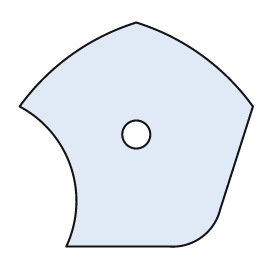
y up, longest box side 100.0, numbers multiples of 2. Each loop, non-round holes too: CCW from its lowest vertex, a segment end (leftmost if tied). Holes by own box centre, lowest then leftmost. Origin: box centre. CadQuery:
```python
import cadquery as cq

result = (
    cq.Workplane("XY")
    .moveTo(-30.0, -48.0)
    .lineTo(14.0, -48.0)
    .threePointArc((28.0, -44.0), (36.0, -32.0))
    .lineTo(50.0, 12.0)
    .threePointArc((28.0, 34.0), (0.0, 48.0))
    .threePointArc((-28.0, 34.0), (-50.0, 12.0))
    .threePointArc((-28.0, -14.0), (-30.0, -48.0))
    .close()
    .moveTo(0.0, 0.0)
    .circle(6.0)
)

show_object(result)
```